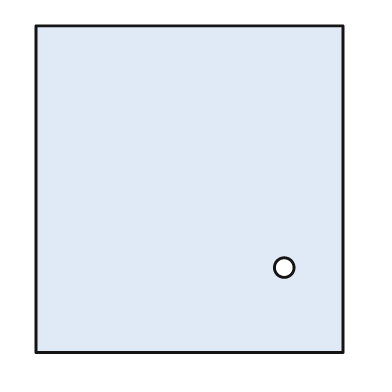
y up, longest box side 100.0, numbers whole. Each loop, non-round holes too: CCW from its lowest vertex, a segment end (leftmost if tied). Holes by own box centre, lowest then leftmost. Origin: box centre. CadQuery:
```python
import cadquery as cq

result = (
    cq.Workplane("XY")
    .moveTo(-47.0, -50.0)
    .lineTo(47.0, -50.0)
    .lineTo(47.0, 50.0)
    .lineTo(-47.0, 50.0)
    .close()
    .moveTo(29.0, -24.0)
    .circle(3.0)
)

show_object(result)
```